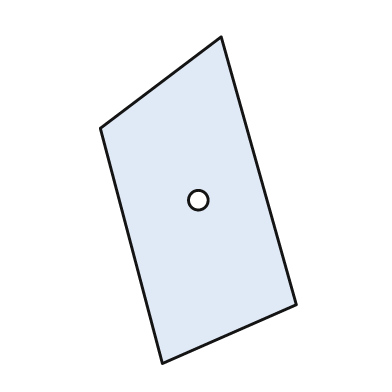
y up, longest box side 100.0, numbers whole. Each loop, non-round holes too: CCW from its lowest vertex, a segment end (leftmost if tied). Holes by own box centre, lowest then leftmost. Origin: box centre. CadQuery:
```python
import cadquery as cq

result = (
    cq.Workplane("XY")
    .moveTo(-11.0, -50.0)
    .lineTo(30.0, -32.0)
    .lineTo(7.0, 50.0)
    .lineTo(-30.0, 22.0)
    .close()
    .moveTo(0.0, 0.0)
    .circle(3.0)
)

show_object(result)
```